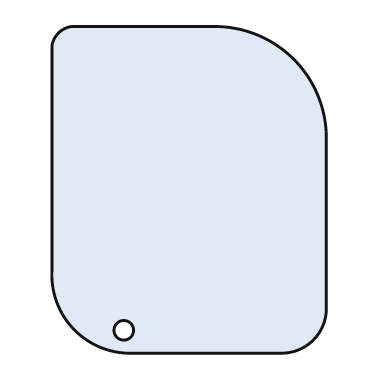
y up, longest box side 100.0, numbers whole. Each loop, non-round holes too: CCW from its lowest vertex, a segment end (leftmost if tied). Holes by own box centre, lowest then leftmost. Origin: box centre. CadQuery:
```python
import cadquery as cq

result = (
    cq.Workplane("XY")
    .moveTo(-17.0, -50.0)
    .lineTo(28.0, -50.0)
    .threePointArc((38.0, -46.0), (42.0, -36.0))
    .lineTo(42.0, 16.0)
    .threePointArc((32.0, 40.0), (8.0, 50.0))
    .lineTo(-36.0, 50.0)
    .threePointArc((-40.0, 48.0), (-42.0, 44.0))
    .lineTo(-42.0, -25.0)
    .threePointArc((-35.0, -43.0), (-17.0, -50.0))
    .close()
    .moveTo(-20.0, -43.0)
    .circle(3.0)
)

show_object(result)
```